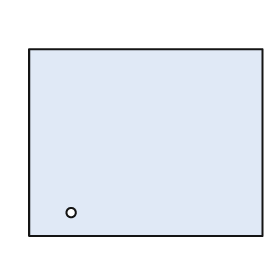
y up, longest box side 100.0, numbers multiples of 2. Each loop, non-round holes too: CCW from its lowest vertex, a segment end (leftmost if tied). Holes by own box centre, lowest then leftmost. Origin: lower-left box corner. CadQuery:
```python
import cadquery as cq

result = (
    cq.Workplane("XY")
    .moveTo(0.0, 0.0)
    .lineTo(100.0, 0.0)
    .lineTo(100.0, 80.0)
    .lineTo(0.0, 80.0)
    .close()
    .moveTo(18.0, 10.0)
    .circle(2.0)
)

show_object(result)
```